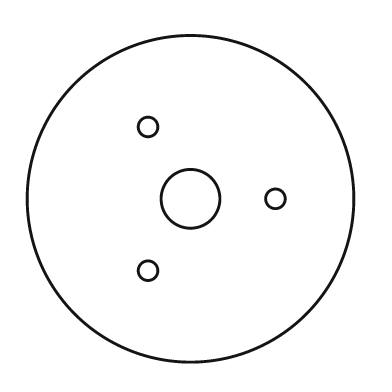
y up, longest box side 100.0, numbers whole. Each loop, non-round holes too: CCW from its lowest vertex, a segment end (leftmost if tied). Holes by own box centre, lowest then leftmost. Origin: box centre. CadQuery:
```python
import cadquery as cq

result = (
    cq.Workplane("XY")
    .moveTo(0.0, 0.0)
    .circle(50.0)
    .moveTo(-13.0, -22.0)
    .circle(3.0)
    .moveTo(0.0, 0.0)
    .circle(9.0)
    .moveTo(26.0, 0.0)
    .circle(3.0)
    .moveTo(-13.0, 22.0)
    .circle(3.0)
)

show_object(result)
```